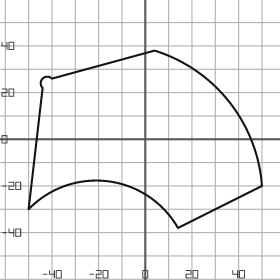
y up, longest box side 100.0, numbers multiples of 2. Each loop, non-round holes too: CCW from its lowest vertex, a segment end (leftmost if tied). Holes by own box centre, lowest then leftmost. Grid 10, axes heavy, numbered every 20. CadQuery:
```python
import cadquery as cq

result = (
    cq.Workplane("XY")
    .moveTo(14.0, -38.0)
    .lineTo(50.0, -20.0)
    .threePointArc((36.0, 16.0), (4.0, 38.0))
    .lineTo(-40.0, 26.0)
    .threePointArc((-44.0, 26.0), (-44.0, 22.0))
    .lineTo(-50.0, -30.0)
    .threePointArc((-16.0, -18.0), (14.0, -38.0))
    .close()
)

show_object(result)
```